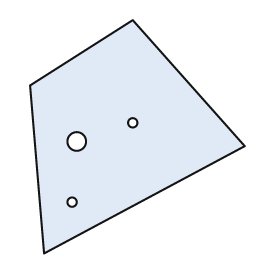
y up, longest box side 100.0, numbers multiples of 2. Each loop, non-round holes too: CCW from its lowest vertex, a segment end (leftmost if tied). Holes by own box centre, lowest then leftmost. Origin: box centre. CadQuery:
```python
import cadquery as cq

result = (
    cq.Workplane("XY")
    .moveTo(-40.0, -50.0)
    .lineTo(46.0, -4.0)
    .lineTo(-2.0, 50.0)
    .lineTo(-46.0, 22.0)
    .close()
    .moveTo(-28.0, -28.0)
    .circle(2.0)
    .moveTo(-26.0, -2.0)
    .circle(4.0)
    .moveTo(-2.0, 6.0)
    .circle(2.0)
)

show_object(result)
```